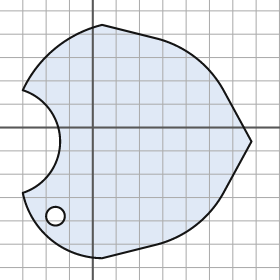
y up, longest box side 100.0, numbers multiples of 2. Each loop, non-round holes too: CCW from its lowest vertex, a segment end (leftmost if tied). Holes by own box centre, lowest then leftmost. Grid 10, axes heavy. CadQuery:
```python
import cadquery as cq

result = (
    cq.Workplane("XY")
    .moveTo(4.0, -56.0)
    .lineTo(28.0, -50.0)
    .threePointArc((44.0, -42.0), (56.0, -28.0))
    .lineTo(68.0, -6.0)
    .lineTo(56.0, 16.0)
    .threePointArc((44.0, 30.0), (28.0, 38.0))
    .lineTo(4.0, 44.0)
    .threePointArc((-16.0, 34.0), (-30.0, 16.0))
    .threePointArc((-14.0, -6.0), (-30.0, -28.0))
    .threePointArc((-18.0, -48.0), (4.0, -56.0))
    .close()
    .moveTo(-16.0, -38.0)
    .circle(4.0)
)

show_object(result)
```